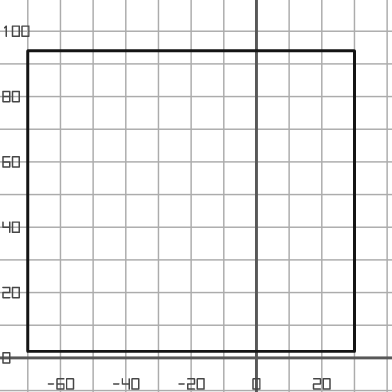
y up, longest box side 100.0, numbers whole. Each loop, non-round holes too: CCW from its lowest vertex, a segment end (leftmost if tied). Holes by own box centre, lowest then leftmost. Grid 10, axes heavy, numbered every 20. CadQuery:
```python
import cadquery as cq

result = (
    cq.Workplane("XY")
    .moveTo(-70.0, 2.0)
    .lineTo(30.0, 2.0)
    .lineTo(30.0, 94.0)
    .lineTo(-70.0, 94.0)
    .close()
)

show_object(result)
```